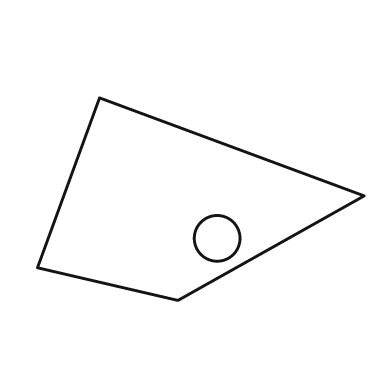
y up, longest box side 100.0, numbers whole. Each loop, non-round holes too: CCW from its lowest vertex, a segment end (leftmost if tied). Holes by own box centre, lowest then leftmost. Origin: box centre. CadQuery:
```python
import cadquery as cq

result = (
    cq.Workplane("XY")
    .moveTo(-7.0, -31.0)
    .lineTo(50.0, 1.0)
    .lineTo(-31.0, 31.0)
    .lineTo(-50.0, -21.0)
    .close()
    .moveTo(5.0, -12.0)
    .circle(7.0)
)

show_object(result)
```